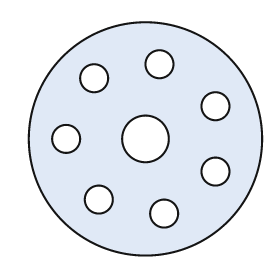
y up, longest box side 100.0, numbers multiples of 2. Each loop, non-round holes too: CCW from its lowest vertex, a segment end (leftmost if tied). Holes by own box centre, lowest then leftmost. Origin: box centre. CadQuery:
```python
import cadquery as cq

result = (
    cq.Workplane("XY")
    .moveTo(0.0, 0.0)
    .circle(50.0)
    .moveTo(8.0, -32.0)
    .circle(6.0)
    .moveTo(-20.0, -26.0)
    .circle(6.0)
    .moveTo(30.0, -14.0)
    .circle(6.0)
    .moveTo(-34.0, 0.0)
    .circle(6.0)
    .moveTo(0.0, 0.0)
    .circle(10.0)
    .moveTo(30.0, 14.0)
    .circle(6.0)
    .moveTo(-22.0, 26.0)
    .circle(6.0)
    .moveTo(6.0, 32.0)
    .circle(6.0)
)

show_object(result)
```